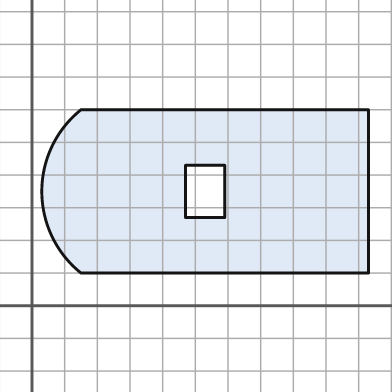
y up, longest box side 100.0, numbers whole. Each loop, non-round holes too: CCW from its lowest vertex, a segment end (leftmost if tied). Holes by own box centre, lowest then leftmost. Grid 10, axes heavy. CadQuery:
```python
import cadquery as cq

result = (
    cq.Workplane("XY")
    .moveTo(15.0, 10.0)
    .lineTo(103.0, 10.0)
    .lineTo(103.0, 60.0)
    .lineTo(15.0, 60.0)
    .threePointArc((3.0, 35.0), (15.0, 10.0))
    .close()
    .moveTo(47.0, 27.0)
    .lineTo(59.0, 27.0)
    .lineTo(59.0, 43.0)
    .lineTo(47.0, 43.0)
    .close()
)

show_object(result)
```